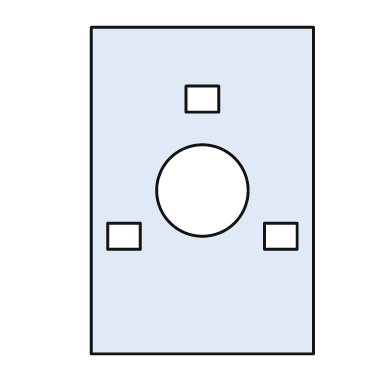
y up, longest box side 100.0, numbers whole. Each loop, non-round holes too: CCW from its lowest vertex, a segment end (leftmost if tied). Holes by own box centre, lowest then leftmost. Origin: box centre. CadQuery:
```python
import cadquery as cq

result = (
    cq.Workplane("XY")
    .moveTo(-34.0, -50.0)
    .lineTo(34.0, -50.0)
    .lineTo(34.0, 50.0)
    .lineTo(-34.0, 50.0)
    .close()
    .moveTo(-29.0, -18.0)
    .lineTo(-19.0, -18.0)
    .lineTo(-19.0, -10.0)
    .lineTo(-29.0, -10.0)
    .close()
    .moveTo(19.0, -18.0)
    .lineTo(29.0, -18.0)
    .lineTo(29.0, -10.0)
    .lineTo(19.0, -10.0)
    .close()
    .moveTo(0.0, 0.0)
    .circle(14.0)
    .moveTo(-5.0, 24.0)
    .lineTo(5.0, 24.0)
    .lineTo(5.0, 32.0)
    .lineTo(-5.0, 32.0)
    .close()
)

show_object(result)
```